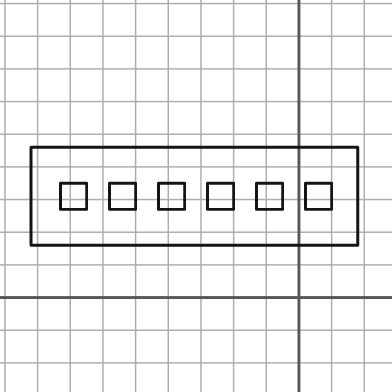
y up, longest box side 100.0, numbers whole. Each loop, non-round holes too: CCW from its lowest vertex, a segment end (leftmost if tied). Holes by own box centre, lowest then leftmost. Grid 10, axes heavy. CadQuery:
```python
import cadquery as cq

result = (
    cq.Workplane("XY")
    .moveTo(-82.0, 16.0)
    .lineTo(18.0, 16.0)
    .lineTo(18.0, 46.0)
    .lineTo(-82.0, 46.0)
    .close()
    .moveTo(-73.0, 27.0)
    .lineTo(-65.0, 27.0)
    .lineTo(-65.0, 35.0)
    .lineTo(-73.0, 35.0)
    .close()
    .moveTo(-58.0, 27.0)
    .lineTo(-50.0, 27.0)
    .lineTo(-50.0, 35.0)
    .lineTo(-58.0, 35.0)
    .close()
    .moveTo(-43.0, 27.0)
    .lineTo(-35.0, 27.0)
    .lineTo(-35.0, 35.0)
    .lineTo(-43.0, 35.0)
    .close()
    .moveTo(-28.0, 27.0)
    .lineTo(-20.0, 27.0)
    .lineTo(-20.0, 35.0)
    .lineTo(-28.0, 35.0)
    .close()
    .moveTo(-13.0, 27.0)
    .lineTo(-5.0, 27.0)
    .lineTo(-5.0, 35.0)
    .lineTo(-13.0, 35.0)
    .close()
    .moveTo(2.0, 27.0)
    .lineTo(10.0, 27.0)
    .lineTo(10.0, 35.0)
    .lineTo(2.0, 35.0)
    .close()
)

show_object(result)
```